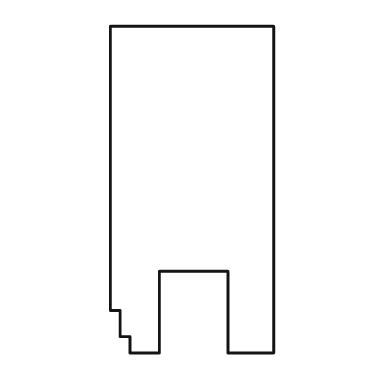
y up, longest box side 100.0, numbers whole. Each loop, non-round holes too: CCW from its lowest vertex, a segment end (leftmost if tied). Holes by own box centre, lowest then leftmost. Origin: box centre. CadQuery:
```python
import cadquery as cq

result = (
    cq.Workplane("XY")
    .moveTo(-19.0, -50.0)
    .lineTo(-10.0, -50.0)
    .lineTo(-10.0, -25.0)
    .lineTo(11.0, -25.0)
    .lineTo(11.0, -50.0)
    .lineTo(25.0, -50.0)
    .lineTo(25.0, 50.0)
    .lineTo(-25.0, 50.0)
    .lineTo(-25.0, -37.0)
    .lineTo(-22.0, -37.0)
    .lineTo(-22.0, -45.0)
    .lineTo(-19.0, -45.0)
    .close()
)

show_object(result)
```